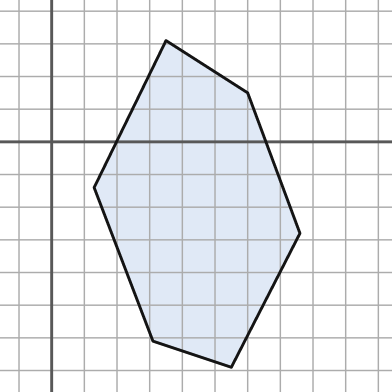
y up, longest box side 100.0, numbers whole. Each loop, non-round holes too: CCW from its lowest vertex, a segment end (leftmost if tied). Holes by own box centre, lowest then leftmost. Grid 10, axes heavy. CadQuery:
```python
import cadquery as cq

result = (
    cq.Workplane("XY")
    .moveTo(55.0, -69.0)
    .lineTo(76.0, -28.0)
    .lineTo(60.0, 15.0)
    .lineTo(35.0, 31.0)
    .lineTo(13.0, -14.0)
    .lineTo(31.0, -61.0)
    .close()
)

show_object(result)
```